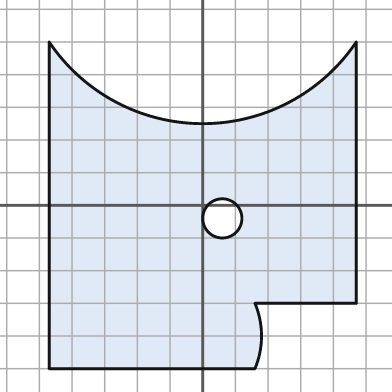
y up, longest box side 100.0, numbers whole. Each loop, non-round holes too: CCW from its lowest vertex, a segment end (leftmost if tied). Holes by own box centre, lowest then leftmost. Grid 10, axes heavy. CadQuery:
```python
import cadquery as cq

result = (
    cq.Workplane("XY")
    .moveTo(-47.0, -50.0)
    .lineTo(16.0, -50.0)
    .threePointArc((18.0, -40.0), (16.0, -30.0))
    .lineTo(47.0, -30.0)
    .lineTo(47.0, 50.0)
    .threePointArc((0.0, 25.0), (-47.0, 50.0))
    .close()
    .moveTo(6.0, -4.0)
    .circle(6.0)
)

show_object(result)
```